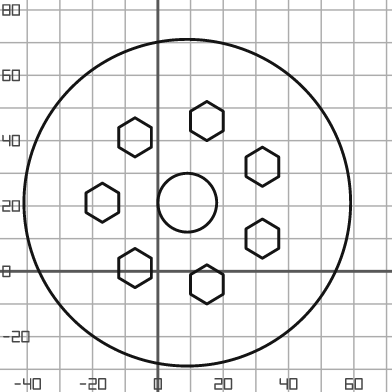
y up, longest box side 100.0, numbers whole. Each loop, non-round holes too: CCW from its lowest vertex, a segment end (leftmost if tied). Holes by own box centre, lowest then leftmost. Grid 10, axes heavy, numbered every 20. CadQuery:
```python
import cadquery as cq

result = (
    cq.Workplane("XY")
    .moveTo(9.0, 21.0)
    .circle(50.0)
    .moveTo(15.0, -10.0)
    .lineTo(20.0, -7.0)
    .lineTo(20.0, -1.0)
    .lineTo(15.0, 2.0)
    .lineTo(10.0, -1.0)
    .lineTo(10.0, -7.0)
    .close()
    .moveTo(-7.0, -5.0)
    .lineTo(-2.0, -2.0)
    .lineTo(-2.0, 4.0)
    .lineTo(-7.0, 7.0)
    .lineTo(-12.0, 4.0)
    .lineTo(-12.0, -2.0)
    .close()
    .moveTo(32.0, 4.0)
    .lineTo(37.0, 7.0)
    .lineTo(37.0, 13.0)
    .lineTo(32.0, 16.0)
    .lineTo(27.0, 13.0)
    .lineTo(27.0, 7.0)
    .close()
    .moveTo(-17.0, 15.0)
    .lineTo(-12.0, 18.0)
    .lineTo(-12.0, 24.0)
    .lineTo(-17.0, 27.0)
    .lineTo(-22.0, 24.0)
    .lineTo(-22.0, 18.0)
    .close()
    .moveTo(9.0, 21.0)
    .circle(9.0)
    .moveTo(32.0, 26.0)
    .lineTo(37.0, 29.0)
    .lineTo(37.0, 35.0)
    .lineTo(32.0, 38.0)
    .lineTo(27.0, 35.0)
    .lineTo(27.0, 29.0)
    .close()
    .moveTo(-7.0, 35.0)
    .lineTo(-2.0, 38.0)
    .lineTo(-2.0, 44.0)
    .lineTo(-7.0, 47.0)
    .lineTo(-12.0, 44.0)
    .lineTo(-12.0, 38.0)
    .close()
    .moveTo(15.0, 40.0)
    .lineTo(20.0, 43.0)
    .lineTo(20.0, 49.0)
    .lineTo(15.0, 52.0)
    .lineTo(10.0, 49.0)
    .lineTo(10.0, 43.0)
    .close()
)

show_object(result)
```